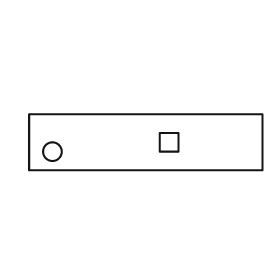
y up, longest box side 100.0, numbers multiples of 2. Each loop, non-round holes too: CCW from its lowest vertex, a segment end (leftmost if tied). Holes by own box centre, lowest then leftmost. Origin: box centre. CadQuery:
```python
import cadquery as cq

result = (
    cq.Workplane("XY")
    .moveTo(-50.0, -12.0)
    .lineTo(50.0, -12.0)
    .lineTo(50.0, 12.0)
    .lineTo(-50.0, 12.0)
    .close()
    .moveTo(-40.0, -4.0)
    .circle(4.0)
    .moveTo(6.0, -4.0)
    .lineTo(14.0, -4.0)
    .lineTo(14.0, 4.0)
    .lineTo(6.0, 4.0)
    .close()
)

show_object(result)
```